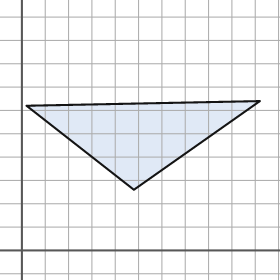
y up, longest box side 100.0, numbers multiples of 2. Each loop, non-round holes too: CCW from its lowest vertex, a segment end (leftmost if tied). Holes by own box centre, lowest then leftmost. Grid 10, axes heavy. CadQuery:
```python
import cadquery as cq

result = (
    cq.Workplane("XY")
    .moveTo(48.0, 26.0)
    .lineTo(102.0, 64.0)
    .lineTo(2.0, 62.0)
    .close()
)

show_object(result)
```